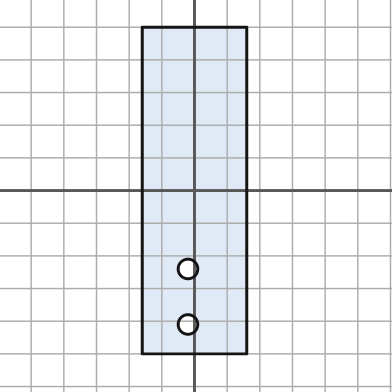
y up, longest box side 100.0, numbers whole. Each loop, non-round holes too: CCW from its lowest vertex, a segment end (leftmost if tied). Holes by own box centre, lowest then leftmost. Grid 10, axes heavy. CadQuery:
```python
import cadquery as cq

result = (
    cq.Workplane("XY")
    .moveTo(-16.0, -50.0)
    .lineTo(16.0, -50.0)
    .lineTo(16.0, 50.0)
    .lineTo(-16.0, 50.0)
    .close()
    .moveTo(-2.0, -41.0)
    .circle(3.0)
    .moveTo(-2.0, -24.0)
    .circle(3.0)
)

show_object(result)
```